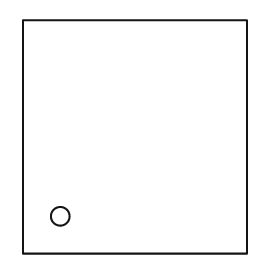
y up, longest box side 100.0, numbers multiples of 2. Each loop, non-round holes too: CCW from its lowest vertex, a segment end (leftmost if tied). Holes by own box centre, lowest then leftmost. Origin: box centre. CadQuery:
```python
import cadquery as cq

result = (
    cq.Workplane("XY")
    .moveTo(-48.0, -50.0)
    .lineTo(48.0, -50.0)
    .lineTo(48.0, 50.0)
    .lineTo(-48.0, 50.0)
    .close()
    .moveTo(-32.0, -34.0)
    .circle(4.0)
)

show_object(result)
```